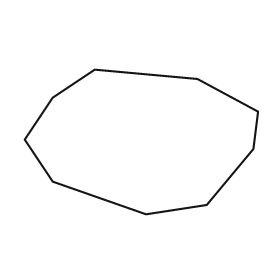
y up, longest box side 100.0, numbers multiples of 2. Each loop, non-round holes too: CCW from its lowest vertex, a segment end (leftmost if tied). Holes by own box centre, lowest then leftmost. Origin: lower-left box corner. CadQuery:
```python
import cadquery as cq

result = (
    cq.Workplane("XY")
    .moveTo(52.0, 0.0)
    .lineTo(78.0, 4.0)
    .lineTo(98.0, 28.0)
    .lineTo(100.0, 44.0)
    .lineTo(74.0, 58.0)
    .lineTo(30.0, 62.0)
    .lineTo(12.0, 50.0)
    .lineTo(0.0, 32.0)
    .lineTo(12.0, 14.0)
    .close()
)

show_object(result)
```